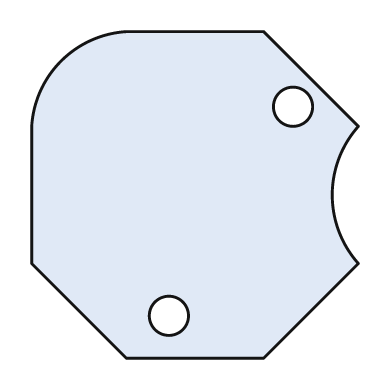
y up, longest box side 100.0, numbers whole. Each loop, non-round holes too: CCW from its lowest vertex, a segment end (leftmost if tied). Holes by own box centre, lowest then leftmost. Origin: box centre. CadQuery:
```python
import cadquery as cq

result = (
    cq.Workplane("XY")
    .moveTo(-21.0, -50.0)
    .lineTo(21.0, -50.0)
    .lineTo(50.0, -21.0)
    .threePointArc((42.0, 0.0), (50.0, 21.0))
    .lineTo(21.0, 50.0)
    .lineTo(-21.0, 50.0)
    .threePointArc((-41.0, 41.0), (-50.0, 21.0))
    .lineTo(-50.0, -21.0)
    .close()
    .moveTo(-8.0, -37.0)
    .circle(6.0)
    .moveTo(30.0, 27.0)
    .circle(6.0)
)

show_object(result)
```